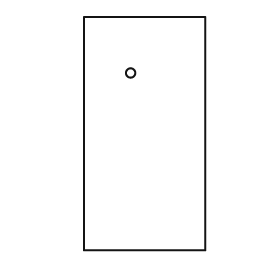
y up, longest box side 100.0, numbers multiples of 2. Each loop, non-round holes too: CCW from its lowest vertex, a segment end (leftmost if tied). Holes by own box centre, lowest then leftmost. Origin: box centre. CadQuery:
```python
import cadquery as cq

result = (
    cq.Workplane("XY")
    .moveTo(-26.0, -50.0)
    .lineTo(26.0, -50.0)
    .lineTo(26.0, 50.0)
    .lineTo(-26.0, 50.0)
    .close()
    .moveTo(-6.0, 26.0)
    .circle(2.0)
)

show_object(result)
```